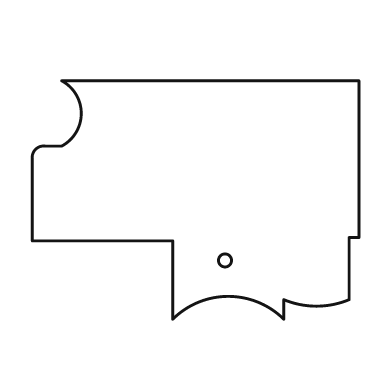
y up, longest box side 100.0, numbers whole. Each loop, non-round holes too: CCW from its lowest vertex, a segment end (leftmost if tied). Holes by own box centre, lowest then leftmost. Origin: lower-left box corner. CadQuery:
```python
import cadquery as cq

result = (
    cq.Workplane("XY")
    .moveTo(43.0, 0.0)
    .threePointArc((60.0, 7.0), (77.0, 0.0))
    .lineTo(77.0, 6.0)
    .threePointArc((87.0, 4.0), (97.0, 6.0))
    .lineTo(97.0, 25.0)
    .lineTo(100.0, 25.0)
    .lineTo(100.0, 73.0)
    .lineTo(9.0, 73.0)
    .threePointArc((15.0, 63.0), (9.0, 53.0))
    .lineTo(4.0, 53.0)
    .threePointArc((1.0, 52.0), (0.0, 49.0))
    .lineTo(0.0, 24.0)
    .lineTo(43.0, 24.0)
    .close()
    .moveTo(59.0, 18.0)
    .circle(2.0)
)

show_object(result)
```